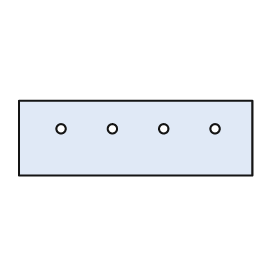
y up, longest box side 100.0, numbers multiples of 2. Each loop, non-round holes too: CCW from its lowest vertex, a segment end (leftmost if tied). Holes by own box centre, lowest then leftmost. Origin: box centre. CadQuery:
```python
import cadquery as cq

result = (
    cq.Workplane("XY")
    .moveTo(-50.0, -16.0)
    .lineTo(50.0, -16.0)
    .lineTo(50.0, 16.0)
    .lineTo(-50.0, 16.0)
    .close()
    .moveTo(-32.0, 4.0)
    .circle(2.0)
    .moveTo(-10.0, 4.0)
    .circle(2.0)
    .moveTo(12.0, 4.0)
    .circle(2.0)
    .moveTo(34.0, 4.0)
    .circle(2.0)
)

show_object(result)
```